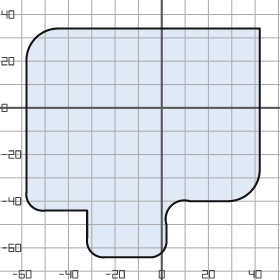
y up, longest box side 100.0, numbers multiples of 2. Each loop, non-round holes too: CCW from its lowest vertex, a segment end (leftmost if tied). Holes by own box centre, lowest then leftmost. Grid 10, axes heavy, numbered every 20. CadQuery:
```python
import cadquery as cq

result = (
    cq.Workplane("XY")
    .moveTo(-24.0, -64.0)
    .lineTo(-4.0, -64.0)
    .threePointArc((0.0, -62.0), (2.0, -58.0))
    .lineTo(2.0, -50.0)
    .threePointArc((4.0, -42.0), (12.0, -40.0))
    .lineTo(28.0, -40.0)
    .threePointArc((38.0, -36.0), (42.0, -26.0))
    .lineTo(42.0, 34.0)
    .lineTo(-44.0, 34.0)
    .threePointArc((-54.0, 30.0), (-58.0, 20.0))
    .lineTo(-58.0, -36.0)
    .threePointArc((-56.0, -42.0), (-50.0, -44.0))
    .lineTo(-32.0, -44.0)
    .lineTo(-32.0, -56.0)
    .threePointArc((-30.0, -62.0), (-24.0, -64.0))
    .close()
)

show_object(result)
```